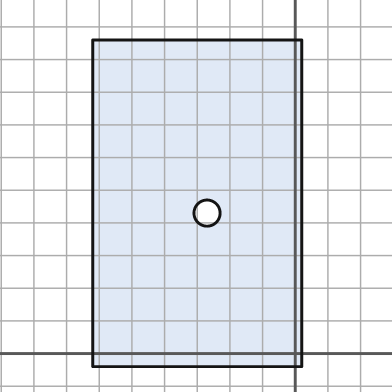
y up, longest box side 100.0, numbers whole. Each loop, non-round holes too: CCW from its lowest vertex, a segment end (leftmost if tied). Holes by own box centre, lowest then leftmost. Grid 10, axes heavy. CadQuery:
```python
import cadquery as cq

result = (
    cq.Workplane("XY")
    .moveTo(-62.0, -4.0)
    .lineTo(2.0, -4.0)
    .lineTo(2.0, 96.0)
    .lineTo(-62.0, 96.0)
    .close()
    .moveTo(-27.0, 43.0)
    .circle(4.0)
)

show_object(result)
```